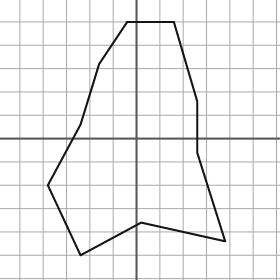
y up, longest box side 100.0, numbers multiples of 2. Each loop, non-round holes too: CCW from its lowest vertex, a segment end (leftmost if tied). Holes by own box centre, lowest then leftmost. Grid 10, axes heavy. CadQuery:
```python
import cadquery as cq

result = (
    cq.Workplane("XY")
    .moveTo(-24.0, -50.0)
    .lineTo(2.0, -36.0)
    .lineTo(38.0, -44.0)
    .lineTo(26.0, -6.0)
    .lineTo(26.0, 16.0)
    .lineTo(16.0, 50.0)
    .lineTo(-4.0, 50.0)
    .lineTo(-16.0, 32.0)
    .lineTo(-24.0, 6.0)
    .lineTo(-38.0, -20.0)
    .close()
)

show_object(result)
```